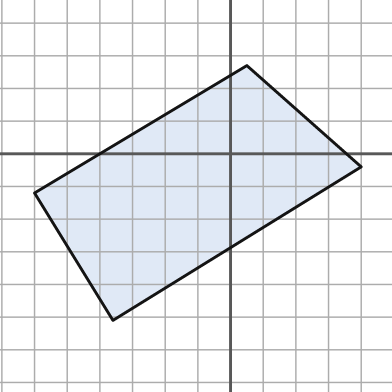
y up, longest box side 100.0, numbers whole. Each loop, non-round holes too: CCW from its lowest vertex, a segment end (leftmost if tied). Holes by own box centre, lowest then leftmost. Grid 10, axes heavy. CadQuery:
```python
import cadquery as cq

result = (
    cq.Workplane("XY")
    .moveTo(-36.0, -51.0)
    .lineTo(40.0, -4.0)
    .lineTo(5.0, 27.0)
    .lineTo(-60.0, -12.0)
    .close()
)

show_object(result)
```